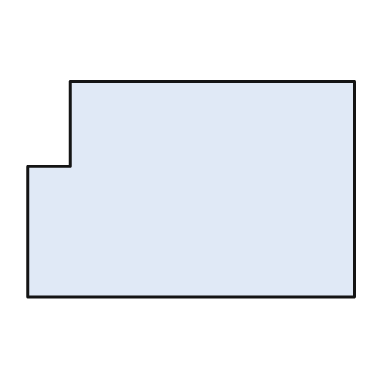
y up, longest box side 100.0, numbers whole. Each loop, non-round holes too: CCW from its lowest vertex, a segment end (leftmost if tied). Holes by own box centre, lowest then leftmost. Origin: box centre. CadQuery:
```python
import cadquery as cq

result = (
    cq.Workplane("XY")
    .moveTo(-50.0, -33.0)
    .lineTo(50.0, -33.0)
    .lineTo(50.0, 33.0)
    .lineTo(-37.0, 33.0)
    .lineTo(-37.0, 7.0)
    .lineTo(-50.0, 7.0)
    .close()
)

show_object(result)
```